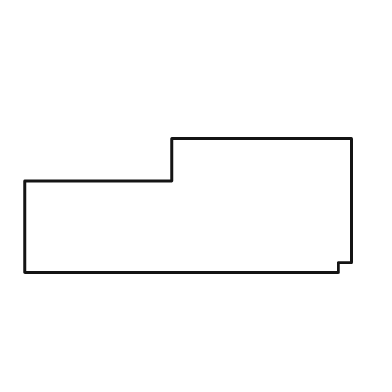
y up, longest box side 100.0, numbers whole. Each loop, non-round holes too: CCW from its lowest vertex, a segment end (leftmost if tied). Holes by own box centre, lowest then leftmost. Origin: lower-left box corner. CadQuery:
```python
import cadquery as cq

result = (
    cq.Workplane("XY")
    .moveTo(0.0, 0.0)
    .lineTo(96.0, 0.0)
    .lineTo(96.0, 3.0)
    .lineTo(100.0, 3.0)
    .lineTo(100.0, 41.0)
    .lineTo(45.0, 41.0)
    .lineTo(45.0, 28.0)
    .lineTo(0.0, 28.0)
    .close()
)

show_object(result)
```